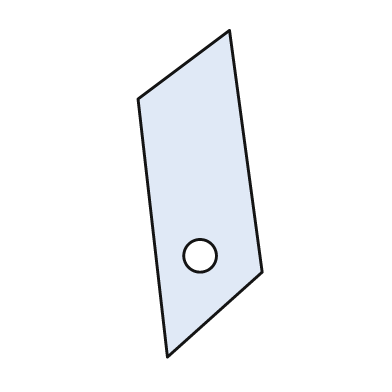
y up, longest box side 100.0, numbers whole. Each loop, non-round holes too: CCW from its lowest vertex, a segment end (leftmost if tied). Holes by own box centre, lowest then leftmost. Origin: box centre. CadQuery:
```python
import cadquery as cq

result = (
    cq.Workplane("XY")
    .moveTo(-10.0, -50.0)
    .lineTo(19.0, -24.0)
    .lineTo(9.0, 50.0)
    .lineTo(-19.0, 29.0)
    .close()
    .moveTo(0.0, -19.0)
    .circle(5.0)
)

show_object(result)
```